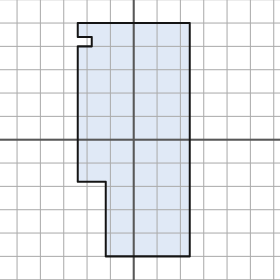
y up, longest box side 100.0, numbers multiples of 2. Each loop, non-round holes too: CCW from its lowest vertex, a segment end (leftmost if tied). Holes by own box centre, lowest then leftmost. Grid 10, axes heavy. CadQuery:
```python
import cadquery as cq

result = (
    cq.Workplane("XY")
    .moveTo(-12.0, -50.0)
    .lineTo(24.0, -50.0)
    .lineTo(24.0, 50.0)
    .lineTo(-24.0, 50.0)
    .lineTo(-24.0, 44.0)
    .lineTo(-18.0, 44.0)
    .lineTo(-18.0, 40.0)
    .lineTo(-24.0, 40.0)
    .lineTo(-24.0, -18.0)
    .lineTo(-12.0, -18.0)
    .close()
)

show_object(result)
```